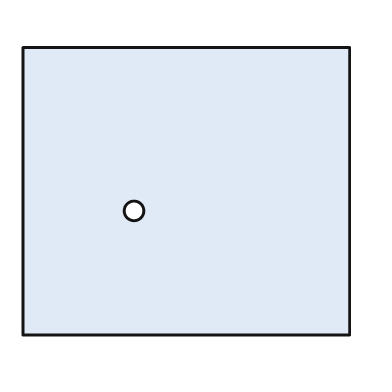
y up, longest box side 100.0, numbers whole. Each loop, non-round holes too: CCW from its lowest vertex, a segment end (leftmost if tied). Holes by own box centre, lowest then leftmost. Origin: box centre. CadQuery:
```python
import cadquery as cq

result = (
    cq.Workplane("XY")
    .moveTo(-50.0, -44.0)
    .lineTo(50.0, -44.0)
    .lineTo(50.0, 44.0)
    .lineTo(-50.0, 44.0)
    .close()
    .moveTo(-16.0, -6.0)
    .circle(3.0)
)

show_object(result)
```